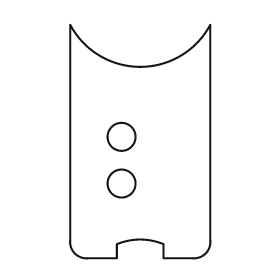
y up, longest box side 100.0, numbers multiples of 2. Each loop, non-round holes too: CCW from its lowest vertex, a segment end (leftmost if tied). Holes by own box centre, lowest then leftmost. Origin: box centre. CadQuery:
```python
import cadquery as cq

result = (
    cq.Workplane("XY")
    .moveTo(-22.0, -50.0)
    .lineTo(-10.0, -50.0)
    .lineTo(-10.0, -44.0)
    .threePointArc((0.0, -42.0), (10.0, -44.0))
    .lineTo(10.0, -50.0)
    .lineTo(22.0, -50.0)
    .threePointArc((28.0, -48.0), (30.0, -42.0))
    .lineTo(30.0, 50.0)
    .threePointArc((0.0, 32.0), (-30.0, 50.0))
    .lineTo(-30.0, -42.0)
    .threePointArc((-28.0, -48.0), (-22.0, -50.0))
    .close()
    .moveTo(-8.0, -18.0)
    .circle(6.0)
    .moveTo(-8.0, 2.0)
    .circle(6.0)
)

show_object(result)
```